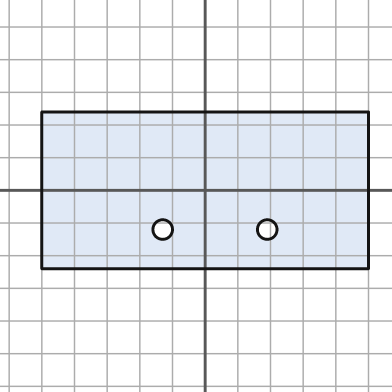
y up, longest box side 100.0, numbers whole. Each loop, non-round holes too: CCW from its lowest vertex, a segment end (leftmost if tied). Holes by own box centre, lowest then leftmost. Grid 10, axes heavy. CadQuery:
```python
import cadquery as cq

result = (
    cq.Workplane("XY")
    .moveTo(-50.0, -24.0)
    .lineTo(50.0, -24.0)
    .lineTo(50.0, 24.0)
    .lineTo(-50.0, 24.0)
    .close()
    .moveTo(-13.0, -12.0)
    .circle(3.0)
    .moveTo(19.0, -12.0)
    .circle(3.0)
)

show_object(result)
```